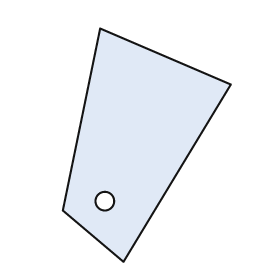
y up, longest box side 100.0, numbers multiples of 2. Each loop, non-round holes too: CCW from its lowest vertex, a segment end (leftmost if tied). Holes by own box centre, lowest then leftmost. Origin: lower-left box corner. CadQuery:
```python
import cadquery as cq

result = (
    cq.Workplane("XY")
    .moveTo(26.0, 0.0)
    .lineTo(72.0, 76.0)
    .lineTo(16.0, 100.0)
    .lineTo(0.0, 22.0)
    .close()
    .moveTo(18.0, 26.0)
    .circle(4.0)
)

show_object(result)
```